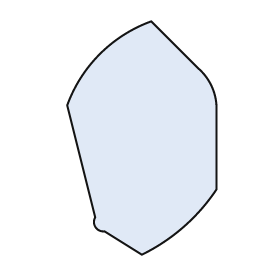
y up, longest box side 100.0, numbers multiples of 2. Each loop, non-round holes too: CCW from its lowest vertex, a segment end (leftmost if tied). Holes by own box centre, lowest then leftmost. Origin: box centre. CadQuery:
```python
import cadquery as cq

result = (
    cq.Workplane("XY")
    .moveTo(0.0, -50.0)
    .threePointArc((18.0, -38.0), (32.0, -22.0))
    .lineTo(32.0, 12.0)
    .threePointArc((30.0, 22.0), (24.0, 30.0))
    .lineTo(4.0, 50.0)
    .threePointArc((-18.0, 36.0), (-32.0, 14.0))
    .lineTo(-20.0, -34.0)
    .threePointArc((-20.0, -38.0), (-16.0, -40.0))
    .close()
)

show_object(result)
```